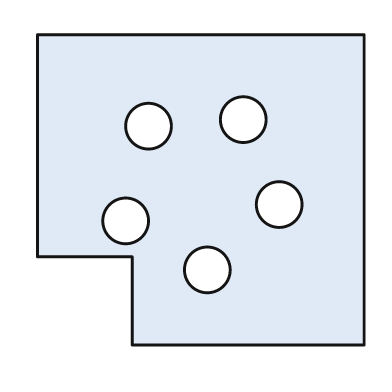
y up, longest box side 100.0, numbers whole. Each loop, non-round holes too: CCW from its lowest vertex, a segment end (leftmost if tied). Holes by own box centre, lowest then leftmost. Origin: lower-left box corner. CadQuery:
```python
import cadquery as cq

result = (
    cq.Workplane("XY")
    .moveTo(29.0, 0.0)
    .lineTo(100.0, 0.0)
    .lineTo(100.0, 95.0)
    .lineTo(0.0, 95.0)
    .lineTo(0.0, 27.0)
    .lineTo(29.0, 27.0)
    .close()
    .moveTo(52.0, 23.0)
    .circle(7.0)
    .moveTo(27.0, 38.0)
    .circle(7.0)
    .moveTo(74.0, 43.0)
    .circle(7.0)
    .moveTo(34.0, 67.0)
    .circle(7.0)
    .moveTo(63.0, 69.0)
    .circle(7.0)
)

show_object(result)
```